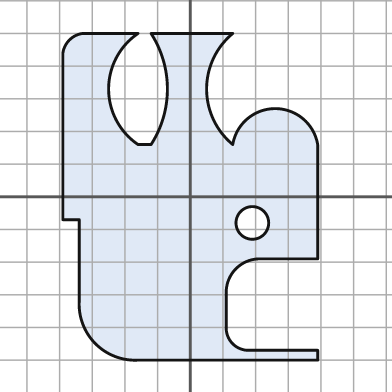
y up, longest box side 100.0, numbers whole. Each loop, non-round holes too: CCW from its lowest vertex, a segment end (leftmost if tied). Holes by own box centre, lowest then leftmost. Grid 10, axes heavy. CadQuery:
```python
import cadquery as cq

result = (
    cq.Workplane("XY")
    .moveTo(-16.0, -50.0)
    .lineTo(39.0, -50.0)
    .lineTo(39.0, -47.0)
    .lineTo(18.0, -47.0)
    .threePointArc((13.0, -45.0), (11.0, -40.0))
    .lineTo(11.0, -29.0)
    .threePointArc((14.0, -22.0), (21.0, -19.0))
    .lineTo(39.0, -19.0)
    .lineTo(39.0, 16.0)
    .threePointArc((26.0, 27.0), (13.0, 16.0))
    .threePointArc((5.0, 33.0), (13.0, 50.0))
    .lineTo(-12.0, 50.0)
    .threePointArc((-7.0, 33.0), (-12.0, 16.0))
    .lineTo(-16.0, 16.0)
    .threePointArc((-25.0, 33.0), (-16.0, 50.0))
    .lineTo(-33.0, 50.0)
    .threePointArc((-37.0, 48.0), (-39.0, 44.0))
    .lineTo(-39.0, -7.0)
    .lineTo(-34.0, -7.0)
    .lineTo(-34.0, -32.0)
    .threePointArc((-29.0, -45.0), (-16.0, -50.0))
    .close()
    .moveTo(19.0, -8.0)
    .circle(5.0)
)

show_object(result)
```